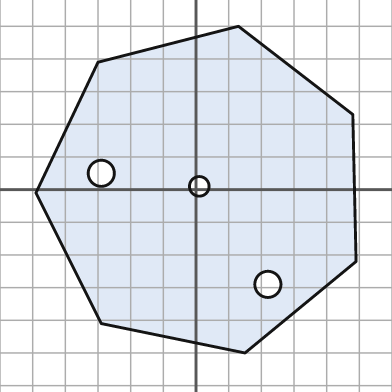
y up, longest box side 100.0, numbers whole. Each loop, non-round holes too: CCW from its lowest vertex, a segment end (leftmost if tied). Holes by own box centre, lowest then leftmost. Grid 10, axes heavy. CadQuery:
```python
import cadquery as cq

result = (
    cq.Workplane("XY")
    .moveTo(15.0, -50.0)
    .lineTo(49.0, -22.0)
    .lineTo(48.0, 23.0)
    .lineTo(13.0, 50.0)
    .lineTo(-30.0, 39.0)
    .lineTo(-49.0, -1.0)
    .lineTo(-29.0, -41.0)
    .close()
    .moveTo(22.0, -29.0)
    .circle(4.0)
    .moveTo(1.0, 1.0)
    .circle(3.0)
    .moveTo(-29.0, 5.0)
    .circle(4.0)
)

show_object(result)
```